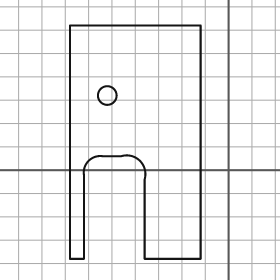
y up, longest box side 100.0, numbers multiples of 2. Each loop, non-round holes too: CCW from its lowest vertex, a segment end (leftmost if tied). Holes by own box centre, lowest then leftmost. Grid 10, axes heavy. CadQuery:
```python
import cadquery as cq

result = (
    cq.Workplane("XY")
    .moveTo(-68.0, -38.0)
    .lineTo(-62.0, -38.0)
    .lineTo(-62.0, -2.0)
    .threePointArc((-60.0, 4.0), (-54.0, 6.0))
    .lineTo(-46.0, 6.0)
    .threePointArc((-38.0, 4.0), (-36.0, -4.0))
    .lineTo(-36.0, -38.0)
    .lineTo(-12.0, -38.0)
    .lineTo(-12.0, 62.0)
    .lineTo(-68.0, 62.0)
    .close()
    .moveTo(-52.0, 32.0)
    .circle(4.0)
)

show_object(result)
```